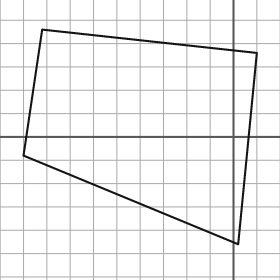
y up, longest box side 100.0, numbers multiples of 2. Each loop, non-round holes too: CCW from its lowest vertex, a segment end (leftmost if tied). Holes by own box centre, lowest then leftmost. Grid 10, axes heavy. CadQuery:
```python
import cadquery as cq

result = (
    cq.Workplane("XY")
    .moveTo(2.0, -46.0)
    .lineTo(10.0, 36.0)
    .lineTo(-82.0, 46.0)
    .lineTo(-90.0, -8.0)
    .close()
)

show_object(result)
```